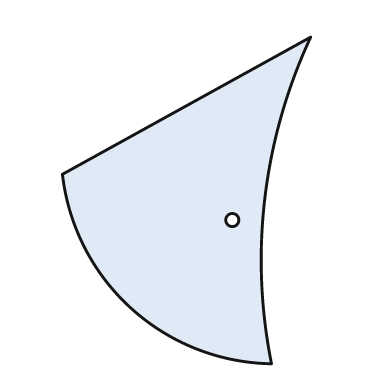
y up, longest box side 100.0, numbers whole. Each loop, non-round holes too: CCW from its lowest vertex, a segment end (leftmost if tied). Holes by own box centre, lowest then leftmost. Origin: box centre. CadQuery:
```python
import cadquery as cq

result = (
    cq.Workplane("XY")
    .moveTo(26.0, -50.0)
    .threePointArc((24.0, 1.0), (38.0, 50.0))
    .lineTo(-38.0, 8.0)
    .threePointArc((-17.0, -33.0), (26.0, -50.0))
    .close()
    .moveTo(14.0, -6.0)
    .circle(2.0)
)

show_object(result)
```